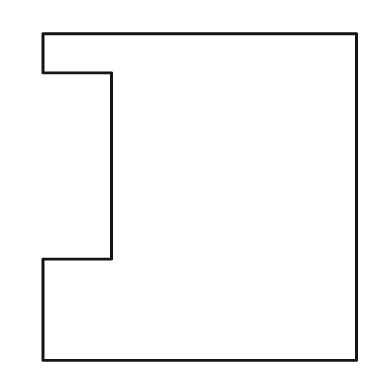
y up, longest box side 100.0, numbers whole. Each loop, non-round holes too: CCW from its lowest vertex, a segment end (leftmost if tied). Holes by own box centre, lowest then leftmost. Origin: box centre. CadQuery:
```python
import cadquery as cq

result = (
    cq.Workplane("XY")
    .moveTo(-48.0, -50.0)
    .lineTo(48.0, -50.0)
    .lineTo(48.0, 50.0)
    .lineTo(-48.0, 50.0)
    .lineTo(-48.0, 38.0)
    .lineTo(-27.0, 38.0)
    .lineTo(-27.0, -19.0)
    .lineTo(-48.0, -19.0)
    .close()
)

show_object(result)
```